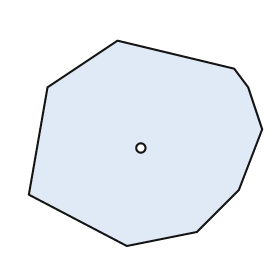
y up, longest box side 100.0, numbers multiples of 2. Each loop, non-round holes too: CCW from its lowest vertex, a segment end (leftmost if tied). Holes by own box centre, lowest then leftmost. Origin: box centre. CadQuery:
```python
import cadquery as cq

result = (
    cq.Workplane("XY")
    .moveTo(-8.0, -44.0)
    .lineTo(22.0, -38.0)
    .lineTo(40.0, -20.0)
    .lineTo(50.0, 6.0)
    .lineTo(44.0, 24.0)
    .lineTo(38.0, 32.0)
    .lineTo(-12.0, 44.0)
    .lineTo(-42.0, 24.0)
    .lineTo(-50.0, -22.0)
    .close()
    .moveTo(-2.0, -2.0)
    .circle(2.0)
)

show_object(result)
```